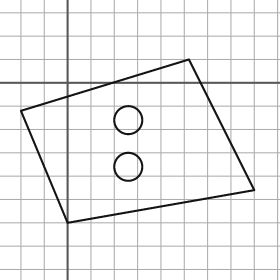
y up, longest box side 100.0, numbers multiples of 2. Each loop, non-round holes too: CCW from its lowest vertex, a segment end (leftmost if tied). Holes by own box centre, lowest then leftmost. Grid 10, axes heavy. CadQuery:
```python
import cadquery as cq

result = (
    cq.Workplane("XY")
    .moveTo(0.0, -60.0)
    .lineTo(80.0, -46.0)
    .lineTo(52.0, 10.0)
    .lineTo(-20.0, -12.0)
    .close()
    .moveTo(26.0, -36.0)
    .circle(6.0)
    .moveTo(26.0, -16.0)
    .circle(6.0)
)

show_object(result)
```